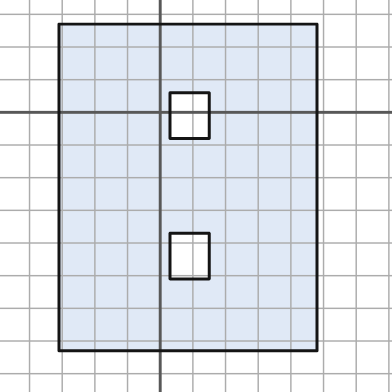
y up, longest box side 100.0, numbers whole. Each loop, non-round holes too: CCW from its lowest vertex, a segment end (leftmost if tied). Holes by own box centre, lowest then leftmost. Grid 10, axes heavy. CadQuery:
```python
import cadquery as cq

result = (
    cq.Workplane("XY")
    .moveTo(-31.0, -73.0)
    .lineTo(48.0, -73.0)
    .lineTo(48.0, 27.0)
    .lineTo(-31.0, 27.0)
    .close()
    .moveTo(3.0, -51.0)
    .lineTo(15.0, -51.0)
    .lineTo(15.0, -37.0)
    .lineTo(3.0, -37.0)
    .close()
    .moveTo(3.0, -8.0)
    .lineTo(15.0, -8.0)
    .lineTo(15.0, 6.0)
    .lineTo(3.0, 6.0)
    .close()
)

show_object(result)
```